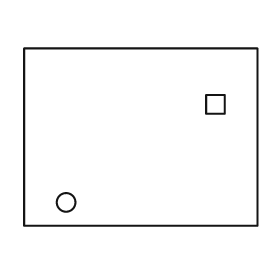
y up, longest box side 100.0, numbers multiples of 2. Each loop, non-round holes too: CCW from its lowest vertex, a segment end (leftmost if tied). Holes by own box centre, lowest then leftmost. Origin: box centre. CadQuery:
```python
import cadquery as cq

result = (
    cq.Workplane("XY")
    .moveTo(-50.0, -38.0)
    .lineTo(50.0, -38.0)
    .lineTo(50.0, 38.0)
    .lineTo(-50.0, 38.0)
    .close()
    .moveTo(-32.0, -28.0)
    .circle(4.0)
    .moveTo(28.0, 10.0)
    .lineTo(36.0, 10.0)
    .lineTo(36.0, 18.0)
    .lineTo(28.0, 18.0)
    .close()
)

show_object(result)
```